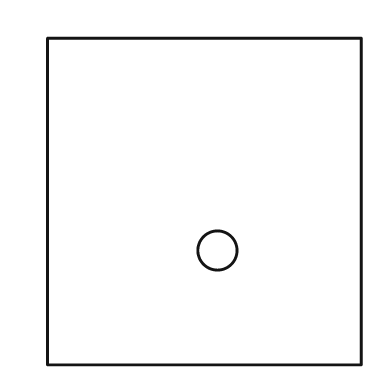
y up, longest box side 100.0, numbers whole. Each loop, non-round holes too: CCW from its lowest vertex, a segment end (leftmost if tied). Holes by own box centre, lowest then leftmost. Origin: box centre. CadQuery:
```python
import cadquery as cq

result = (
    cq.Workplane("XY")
    .moveTo(-48.0, -50.0)
    .lineTo(48.0, -50.0)
    .lineTo(48.0, 50.0)
    .lineTo(-48.0, 50.0)
    .close()
    .moveTo(4.0, -15.0)
    .circle(6.0)
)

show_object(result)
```